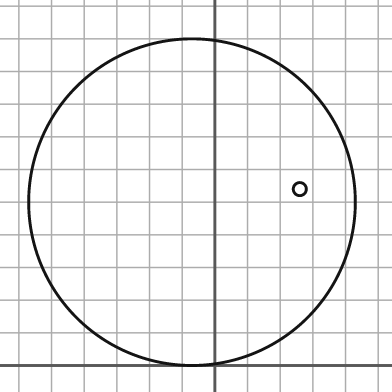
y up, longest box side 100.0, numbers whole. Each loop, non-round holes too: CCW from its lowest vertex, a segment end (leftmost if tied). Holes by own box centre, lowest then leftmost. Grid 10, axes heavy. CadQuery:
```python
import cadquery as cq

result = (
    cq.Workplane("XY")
    .moveTo(-7.0, 50.0)
    .circle(50.0)
    .moveTo(26.0, 54.0)
    .circle(2.0)
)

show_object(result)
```